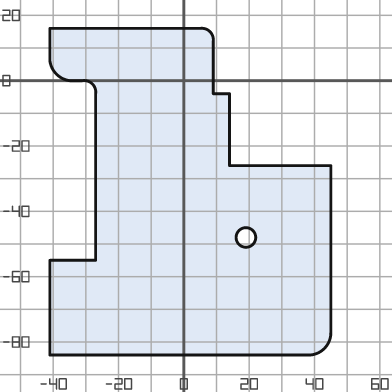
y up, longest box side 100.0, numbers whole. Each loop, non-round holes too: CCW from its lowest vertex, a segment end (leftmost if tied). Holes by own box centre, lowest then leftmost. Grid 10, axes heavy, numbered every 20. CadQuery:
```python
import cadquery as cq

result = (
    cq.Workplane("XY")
    .moveTo(-41.0, -84.0)
    .lineTo(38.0, -84.0)
    .threePointArc((43.0, -82.0), (45.0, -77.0))
    .lineTo(45.0, -26.0)
    .lineTo(14.0, -26.0)
    .lineTo(14.0, -4.0)
    .lineTo(9.0, -4.0)
    .lineTo(9.0, 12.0)
    .threePointArc((8.0, 15.0), (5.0, 16.0))
    .lineTo(-41.0, 16.0)
    .lineTo(-41.0, 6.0)
    .threePointArc((-39.0, 2.0), (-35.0, 0.0))
    .lineTo(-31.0, 0.0)
    .threePointArc((-28.0, -1.0), (-27.0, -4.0))
    .lineTo(-27.0, -55.0)
    .lineTo(-41.0, -55.0)
    .close()
    .moveTo(19.0, -48.0)
    .circle(3.0)
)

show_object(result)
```